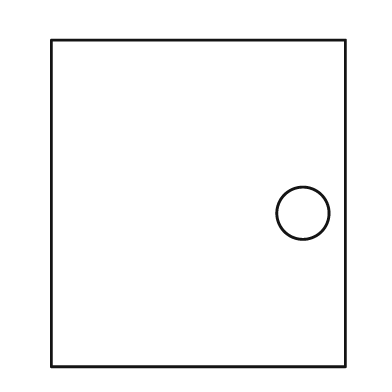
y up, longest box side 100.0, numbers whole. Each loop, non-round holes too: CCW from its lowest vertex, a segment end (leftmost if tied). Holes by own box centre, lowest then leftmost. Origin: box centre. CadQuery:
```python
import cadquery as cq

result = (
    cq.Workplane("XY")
    .moveTo(-45.0, -50.0)
    .lineTo(45.0, -50.0)
    .lineTo(45.0, 50.0)
    .lineTo(-45.0, 50.0)
    .close()
    .moveTo(32.0, -3.0)
    .circle(8.0)
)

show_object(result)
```